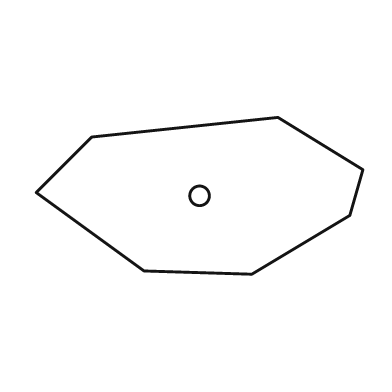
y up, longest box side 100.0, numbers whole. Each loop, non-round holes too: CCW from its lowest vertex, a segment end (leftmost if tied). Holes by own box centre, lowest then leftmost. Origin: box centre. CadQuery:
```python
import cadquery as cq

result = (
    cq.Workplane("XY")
    .moveTo(16.0, -24.0)
    .lineTo(46.0, -6.0)
    .lineTo(50.0, 8.0)
    .lineTo(24.0, 24.0)
    .lineTo(-33.0, 18.0)
    .lineTo(-50.0, 1.0)
    .lineTo(-17.0, -23.0)
    .close()
    .moveTo(0.0, 0.0)
    .circle(3.0)
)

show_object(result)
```